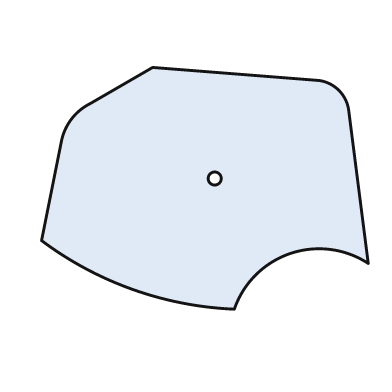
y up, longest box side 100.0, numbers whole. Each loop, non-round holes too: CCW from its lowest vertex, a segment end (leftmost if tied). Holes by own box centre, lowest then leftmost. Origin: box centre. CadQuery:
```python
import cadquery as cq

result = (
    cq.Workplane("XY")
    .moveTo(9.0, -37.0)
    .threePointArc((26.0, -20.0), (50.0, -23.0))
    .lineTo(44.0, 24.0)
    .threePointArc((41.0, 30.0), (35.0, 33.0))
    .lineTo(-16.0, 37.0)
    .lineTo(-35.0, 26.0)
    .threePointArc((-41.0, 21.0), (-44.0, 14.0))
    .lineTo(-50.0, -16.0)
    .threePointArc((-22.0, -31.0), (9.0, -37.0))
    .close()
    .moveTo(3.0, 3.0)
    .circle(2.0)
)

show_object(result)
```